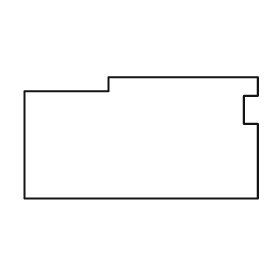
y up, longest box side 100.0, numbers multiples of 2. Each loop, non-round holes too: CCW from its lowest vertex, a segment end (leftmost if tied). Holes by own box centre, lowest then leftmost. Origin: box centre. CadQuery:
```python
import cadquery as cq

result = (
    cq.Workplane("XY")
    .moveTo(-50.0, -26.0)
    .lineTo(50.0, -26.0)
    .lineTo(50.0, 6.0)
    .lineTo(44.0, 6.0)
    .lineTo(44.0, 18.0)
    .lineTo(50.0, 18.0)
    .lineTo(50.0, 26.0)
    .lineTo(-14.0, 26.0)
    .lineTo(-14.0, 20.0)
    .lineTo(-50.0, 20.0)
    .close()
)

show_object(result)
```